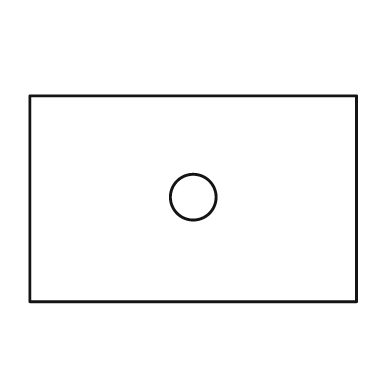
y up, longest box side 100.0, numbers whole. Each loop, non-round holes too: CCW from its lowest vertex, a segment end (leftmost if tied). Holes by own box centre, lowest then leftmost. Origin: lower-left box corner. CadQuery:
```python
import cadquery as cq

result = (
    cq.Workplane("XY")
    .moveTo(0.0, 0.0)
    .lineTo(100.0, 0.0)
    .lineTo(100.0, 63.0)
    .lineTo(0.0, 63.0)
    .close()
    .moveTo(50.0, 32.0)
    .circle(7.0)
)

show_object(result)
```